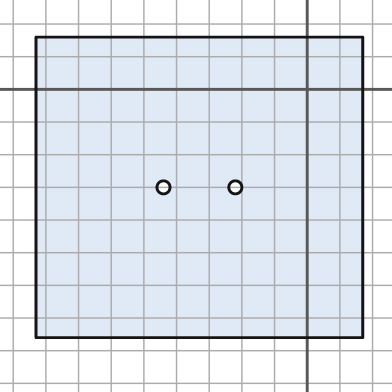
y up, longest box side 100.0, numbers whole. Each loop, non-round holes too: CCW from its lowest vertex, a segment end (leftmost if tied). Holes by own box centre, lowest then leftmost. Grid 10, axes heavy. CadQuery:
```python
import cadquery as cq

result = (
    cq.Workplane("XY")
    .moveTo(-83.0, -76.0)
    .lineTo(17.0, -76.0)
    .lineTo(17.0, 16.0)
    .lineTo(-83.0, 16.0)
    .close()
    .moveTo(-44.0, -30.0)
    .circle(2.0)
    .moveTo(-22.0, -30.0)
    .circle(2.0)
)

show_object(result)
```